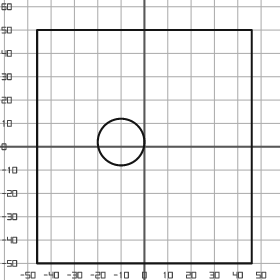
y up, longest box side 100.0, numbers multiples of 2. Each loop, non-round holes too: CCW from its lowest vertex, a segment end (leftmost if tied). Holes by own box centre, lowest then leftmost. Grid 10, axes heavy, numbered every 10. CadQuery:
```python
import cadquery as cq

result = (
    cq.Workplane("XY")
    .moveTo(-46.0, -50.0)
    .lineTo(46.0, -50.0)
    .lineTo(46.0, 50.0)
    .lineTo(-46.0, 50.0)
    .close()
    .moveTo(-10.0, 2.0)
    .circle(10.0)
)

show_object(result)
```